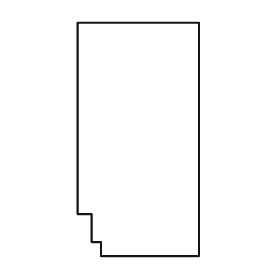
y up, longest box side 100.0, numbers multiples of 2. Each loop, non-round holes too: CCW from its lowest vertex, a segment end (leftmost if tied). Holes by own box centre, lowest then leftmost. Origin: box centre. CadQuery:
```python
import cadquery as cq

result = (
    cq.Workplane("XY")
    .moveTo(-16.0, -50.0)
    .lineTo(26.0, -50.0)
    .lineTo(26.0, 50.0)
    .lineTo(-26.0, 50.0)
    .lineTo(-26.0, -32.0)
    .lineTo(-20.0, -32.0)
    .lineTo(-20.0, -44.0)
    .lineTo(-16.0, -44.0)
    .close()
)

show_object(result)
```